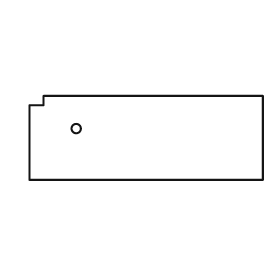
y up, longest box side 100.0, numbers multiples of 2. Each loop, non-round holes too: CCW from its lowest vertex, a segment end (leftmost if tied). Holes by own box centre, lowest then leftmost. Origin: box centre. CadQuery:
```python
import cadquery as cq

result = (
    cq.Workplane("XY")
    .moveTo(-50.0, -18.0)
    .lineTo(50.0, -18.0)
    .lineTo(50.0, 18.0)
    .lineTo(-44.0, 18.0)
    .lineTo(-44.0, 14.0)
    .lineTo(-50.0, 14.0)
    .close()
    .moveTo(-30.0, 4.0)
    .circle(2.0)
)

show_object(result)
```